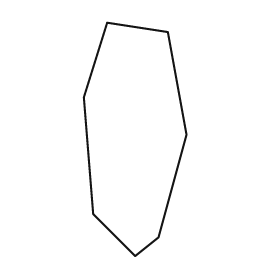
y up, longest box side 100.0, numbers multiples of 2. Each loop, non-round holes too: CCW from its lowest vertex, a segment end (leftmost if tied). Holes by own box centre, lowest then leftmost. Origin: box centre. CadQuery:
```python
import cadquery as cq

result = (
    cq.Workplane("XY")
    .moveTo(0.0, -50.0)
    .lineTo(10.0, -42.0)
    .lineTo(22.0, 2.0)
    .lineTo(14.0, 46.0)
    .lineTo(-12.0, 50.0)
    .lineTo(-22.0, 18.0)
    .lineTo(-18.0, -32.0)
    .close()
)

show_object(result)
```